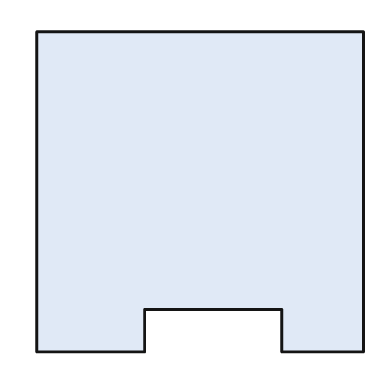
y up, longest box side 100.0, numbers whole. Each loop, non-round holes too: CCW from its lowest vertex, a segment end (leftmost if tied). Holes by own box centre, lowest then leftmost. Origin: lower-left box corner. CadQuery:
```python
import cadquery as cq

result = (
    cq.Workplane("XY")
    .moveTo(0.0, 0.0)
    .lineTo(33.0, 0.0)
    .lineTo(33.0, 13.0)
    .lineTo(75.0, 13.0)
    .lineTo(75.0, 0.0)
    .lineTo(100.0, 0.0)
    .lineTo(100.0, 98.0)
    .lineTo(0.0, 98.0)
    .close()
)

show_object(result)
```